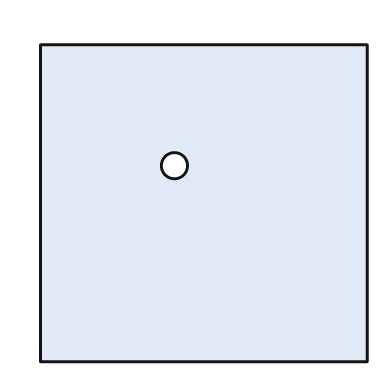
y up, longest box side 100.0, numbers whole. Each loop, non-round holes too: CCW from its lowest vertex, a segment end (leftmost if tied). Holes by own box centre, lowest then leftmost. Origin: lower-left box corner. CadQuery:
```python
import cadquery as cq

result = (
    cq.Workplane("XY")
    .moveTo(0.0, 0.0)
    .lineTo(100.0, 0.0)
    .lineTo(100.0, 97.0)
    .lineTo(0.0, 97.0)
    .close()
    .moveTo(41.0, 60.0)
    .circle(4.0)
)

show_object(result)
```